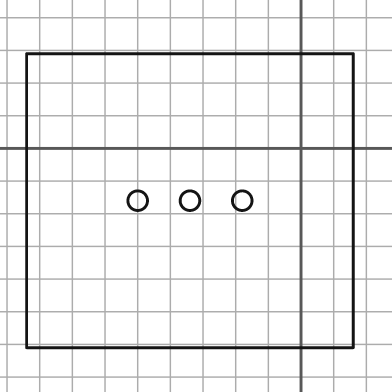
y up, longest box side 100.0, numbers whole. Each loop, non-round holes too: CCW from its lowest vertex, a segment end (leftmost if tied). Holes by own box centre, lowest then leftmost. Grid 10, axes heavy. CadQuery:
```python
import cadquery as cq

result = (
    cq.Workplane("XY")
    .moveTo(-84.0, -61.0)
    .lineTo(16.0, -61.0)
    .lineTo(16.0, 29.0)
    .lineTo(-84.0, 29.0)
    .close()
    .moveTo(-50.0, -16.0)
    .circle(3.0)
    .moveTo(-34.0, -16.0)
    .circle(3.0)
    .moveTo(-18.0, -16.0)
    .circle(3.0)
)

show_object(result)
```